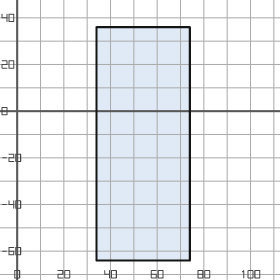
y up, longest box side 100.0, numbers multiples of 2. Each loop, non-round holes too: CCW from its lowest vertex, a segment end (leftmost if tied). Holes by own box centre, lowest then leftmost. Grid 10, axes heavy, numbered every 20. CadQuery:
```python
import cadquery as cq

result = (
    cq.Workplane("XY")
    .moveTo(34.0, -64.0)
    .lineTo(74.0, -64.0)
    .lineTo(74.0, 36.0)
    .lineTo(34.0, 36.0)
    .close()
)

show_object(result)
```